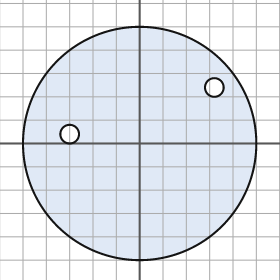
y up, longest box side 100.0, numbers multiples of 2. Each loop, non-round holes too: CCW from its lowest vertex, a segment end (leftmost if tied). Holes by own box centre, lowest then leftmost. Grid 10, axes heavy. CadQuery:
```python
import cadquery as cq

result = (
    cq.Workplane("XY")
    .moveTo(0.0, 0.0)
    .circle(50.0)
    .moveTo(-30.0, 4.0)
    .circle(4.0)
    .moveTo(32.0, 24.0)
    .circle(4.0)
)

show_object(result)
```